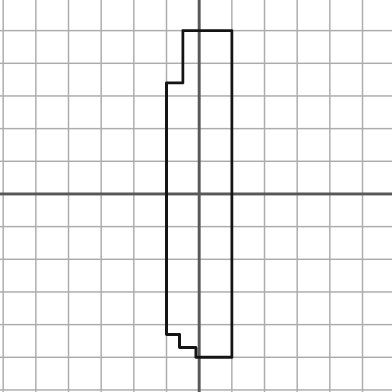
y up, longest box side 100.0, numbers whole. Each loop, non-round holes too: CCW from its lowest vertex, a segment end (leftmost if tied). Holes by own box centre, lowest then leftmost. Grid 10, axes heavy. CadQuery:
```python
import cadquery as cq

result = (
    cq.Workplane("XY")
    .moveTo(-1.0, -50.0)
    .lineTo(10.0, -50.0)
    .lineTo(10.0, 50.0)
    .lineTo(-5.0, 50.0)
    .lineTo(-5.0, 34.0)
    .lineTo(-10.0, 34.0)
    .lineTo(-10.0, -43.0)
    .lineTo(-6.0, -43.0)
    .lineTo(-6.0, -47.0)
    .lineTo(-1.0, -47.0)
    .close()
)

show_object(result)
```